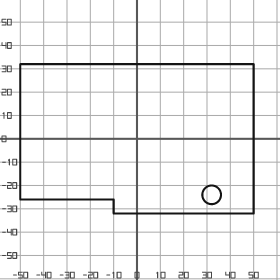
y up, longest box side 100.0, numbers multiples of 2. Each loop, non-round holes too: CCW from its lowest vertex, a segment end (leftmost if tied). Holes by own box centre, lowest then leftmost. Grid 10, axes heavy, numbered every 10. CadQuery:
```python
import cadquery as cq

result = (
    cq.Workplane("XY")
    .moveTo(-10.0, -32.0)
    .lineTo(50.0, -32.0)
    .lineTo(50.0, 32.0)
    .lineTo(-50.0, 32.0)
    .lineTo(-50.0, -26.0)
    .lineTo(-10.0, -26.0)
    .close()
    .moveTo(32.0, -24.0)
    .circle(4.0)
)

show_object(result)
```